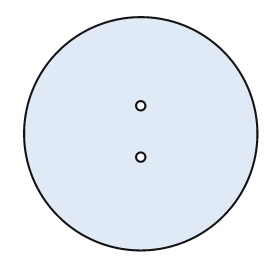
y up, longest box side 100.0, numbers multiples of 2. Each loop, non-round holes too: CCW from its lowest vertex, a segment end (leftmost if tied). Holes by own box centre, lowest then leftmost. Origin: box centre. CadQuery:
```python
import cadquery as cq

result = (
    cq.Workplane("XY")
    .moveTo(0.0, 0.0)
    .circle(50.0)
    .moveTo(0.0, -10.0)
    .circle(2.0)
    .moveTo(0.0, 12.0)
    .circle(2.0)
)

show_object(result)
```